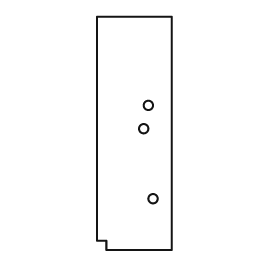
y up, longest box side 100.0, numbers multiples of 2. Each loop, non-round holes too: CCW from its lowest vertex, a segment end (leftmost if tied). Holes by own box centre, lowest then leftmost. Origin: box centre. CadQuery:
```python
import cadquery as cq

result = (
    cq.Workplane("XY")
    .moveTo(-12.0, -50.0)
    .lineTo(16.0, -50.0)
    .lineTo(16.0, 50.0)
    .lineTo(-16.0, 50.0)
    .lineTo(-16.0, -46.0)
    .lineTo(-12.0, -46.0)
    .close()
    .moveTo(8.0, -28.0)
    .circle(2.0)
    .moveTo(4.0, 2.0)
    .circle(2.0)
    .moveTo(6.0, 12.0)
    .circle(2.0)
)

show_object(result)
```